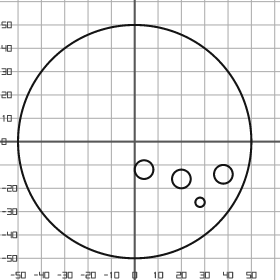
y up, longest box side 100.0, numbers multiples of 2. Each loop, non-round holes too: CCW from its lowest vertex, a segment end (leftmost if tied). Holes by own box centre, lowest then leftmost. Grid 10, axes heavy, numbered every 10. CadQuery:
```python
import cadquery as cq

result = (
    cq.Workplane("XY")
    .moveTo(0.0, 0.0)
    .circle(50.0)
    .moveTo(28.0, -26.0)
    .circle(2.0)
    .moveTo(20.0, -16.0)
    .circle(4.0)
    .moveTo(38.0, -14.0)
    .circle(4.0)
    .moveTo(4.0, -12.0)
    .circle(4.0)
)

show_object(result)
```